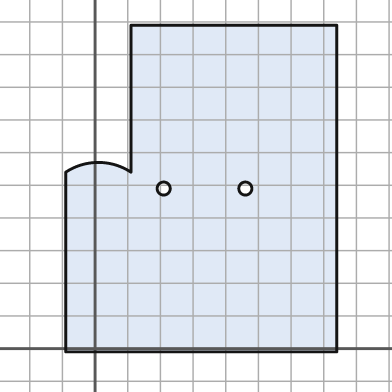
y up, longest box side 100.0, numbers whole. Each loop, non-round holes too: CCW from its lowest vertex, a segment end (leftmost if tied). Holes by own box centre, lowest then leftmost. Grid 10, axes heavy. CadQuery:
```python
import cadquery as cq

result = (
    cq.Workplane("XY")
    .moveTo(-9.0, -1.0)
    .lineTo(74.0, -1.0)
    .lineTo(74.0, 99.0)
    .lineTo(11.0, 99.0)
    .lineTo(11.0, 54.0)
    .threePointArc((1.0, 57.0), (-9.0, 54.0))
    .close()
    .moveTo(21.0, 49.0)
    .circle(2.0)
    .moveTo(46.0, 49.0)
    .circle(2.0)
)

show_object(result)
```